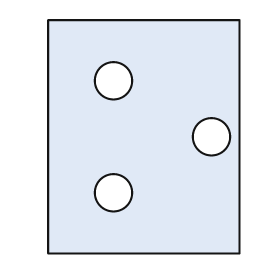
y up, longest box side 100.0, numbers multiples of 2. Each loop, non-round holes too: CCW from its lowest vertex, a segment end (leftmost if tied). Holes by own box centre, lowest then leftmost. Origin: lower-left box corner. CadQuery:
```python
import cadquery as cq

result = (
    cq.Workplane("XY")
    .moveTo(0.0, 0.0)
    .lineTo(82.0, 0.0)
    .lineTo(82.0, 100.0)
    .lineTo(0.0, 100.0)
    .close()
    .moveTo(28.0, 26.0)
    .circle(8.0)
    .moveTo(70.0, 50.0)
    .circle(8.0)
    .moveTo(28.0, 74.0)
    .circle(8.0)
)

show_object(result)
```